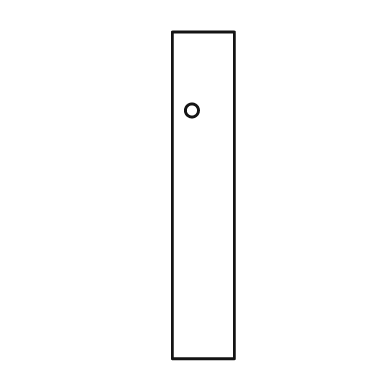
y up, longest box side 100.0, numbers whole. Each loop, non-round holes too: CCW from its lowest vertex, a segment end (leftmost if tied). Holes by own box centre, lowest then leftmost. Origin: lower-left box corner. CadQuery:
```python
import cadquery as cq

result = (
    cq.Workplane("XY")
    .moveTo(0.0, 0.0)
    .lineTo(19.0, 0.0)
    .lineTo(19.0, 100.0)
    .lineTo(0.0, 100.0)
    .close()
    .moveTo(6.0, 76.0)
    .circle(2.0)
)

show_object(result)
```